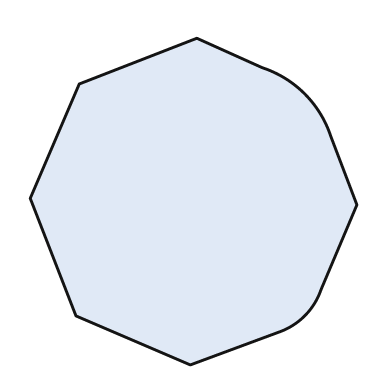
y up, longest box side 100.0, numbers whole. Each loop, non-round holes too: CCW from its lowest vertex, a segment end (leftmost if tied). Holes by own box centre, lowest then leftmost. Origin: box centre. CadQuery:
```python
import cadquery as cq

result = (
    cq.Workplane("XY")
    .moveTo(-1.0, -50.0)
    .lineTo(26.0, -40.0)
    .threePointArc((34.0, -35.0), (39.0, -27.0))
    .lineTo(50.0, -1.0)
    .lineTo(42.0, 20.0)
    .threePointArc((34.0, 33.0), (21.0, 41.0))
    .lineTo(1.0, 50.0)
    .lineTo(-35.0, 36.0)
    .lineTo(-50.0, 1.0)
    .lineTo(-36.0, -35.0)
    .close()
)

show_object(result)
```